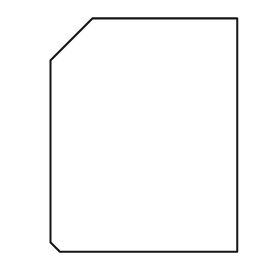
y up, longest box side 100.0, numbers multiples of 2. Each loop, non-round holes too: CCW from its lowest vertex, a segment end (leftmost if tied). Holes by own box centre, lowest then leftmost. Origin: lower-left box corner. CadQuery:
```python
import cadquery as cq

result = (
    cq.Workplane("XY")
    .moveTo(4.0, 0.0)
    .lineTo(80.0, 0.0)
    .lineTo(80.0, 100.0)
    .lineTo(18.0, 100.0)
    .lineTo(0.0, 82.0)
    .lineTo(0.0, 4.0)
    .close()
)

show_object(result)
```